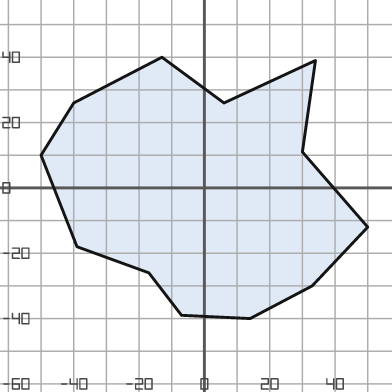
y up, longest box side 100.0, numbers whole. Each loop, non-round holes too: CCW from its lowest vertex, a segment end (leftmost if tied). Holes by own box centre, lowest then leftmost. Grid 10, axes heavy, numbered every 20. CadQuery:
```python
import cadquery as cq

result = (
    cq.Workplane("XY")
    .moveTo(14.0, -40.0)
    .lineTo(33.0, -30.0)
    .lineTo(50.0, -12.0)
    .lineTo(30.0, 11.0)
    .lineTo(34.0, 39.0)
    .lineTo(6.0, 26.0)
    .lineTo(-13.0, 40.0)
    .lineTo(-40.0, 26.0)
    .lineTo(-50.0, 10.0)
    .lineTo(-39.0, -18.0)
    .lineTo(-17.0, -26.0)
    .lineTo(-7.0, -39.0)
    .close()
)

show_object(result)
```